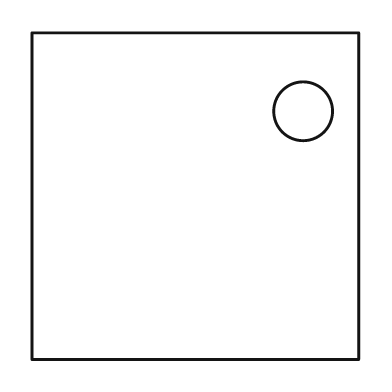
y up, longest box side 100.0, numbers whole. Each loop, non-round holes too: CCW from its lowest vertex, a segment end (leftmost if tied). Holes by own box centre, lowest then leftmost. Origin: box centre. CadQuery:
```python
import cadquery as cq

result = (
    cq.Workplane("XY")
    .moveTo(-50.0, -50.0)
    .lineTo(50.0, -50.0)
    .lineTo(50.0, 50.0)
    .lineTo(-50.0, 50.0)
    .close()
    .moveTo(33.0, 26.0)
    .circle(9.0)
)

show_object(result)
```